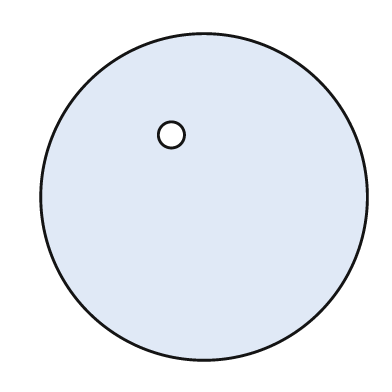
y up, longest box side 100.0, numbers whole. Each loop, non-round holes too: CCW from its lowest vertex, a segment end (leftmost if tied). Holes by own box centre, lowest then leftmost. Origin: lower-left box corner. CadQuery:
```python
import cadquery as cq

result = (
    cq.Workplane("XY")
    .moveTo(50.0, 50.0)
    .circle(50.0)
    .moveTo(40.0, 69.0)
    .circle(4.0)
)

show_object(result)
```